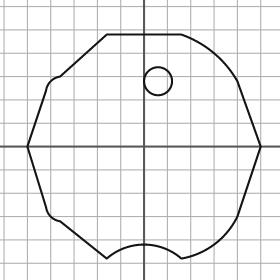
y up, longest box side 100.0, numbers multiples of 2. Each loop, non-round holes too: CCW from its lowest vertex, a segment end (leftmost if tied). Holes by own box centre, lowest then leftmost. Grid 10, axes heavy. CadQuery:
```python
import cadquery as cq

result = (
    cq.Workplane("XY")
    .moveTo(-16.0, -48.0)
    .threePointArc((0.0, -42.0), (16.0, -48.0))
    .threePointArc((30.0, -42.0), (40.0, -30.0))
    .lineTo(50.0, 0.0)
    .lineTo(40.0, 28.0)
    .threePointArc((30.0, 40.0), (16.0, 48.0))
    .lineTo(-16.0, 48.0)
    .lineTo(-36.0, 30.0)
    .threePointArc((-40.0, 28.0), (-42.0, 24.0))
    .lineTo(-50.0, 0.0)
    .lineTo(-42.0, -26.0)
    .threePointArc((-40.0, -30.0), (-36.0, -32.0))
    .close()
    .moveTo(6.0, 28.0)
    .circle(6.0)
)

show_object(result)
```